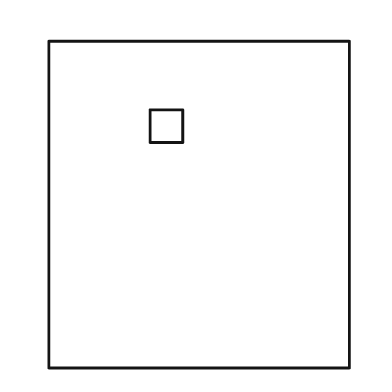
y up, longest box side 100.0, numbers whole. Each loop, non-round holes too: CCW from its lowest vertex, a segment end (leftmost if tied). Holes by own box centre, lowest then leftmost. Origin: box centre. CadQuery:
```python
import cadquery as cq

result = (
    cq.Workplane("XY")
    .moveTo(-46.0, -50.0)
    .lineTo(46.0, -50.0)
    .lineTo(46.0, 50.0)
    .lineTo(-46.0, 50.0)
    .close()
    .moveTo(-15.0, 19.0)
    .lineTo(-5.0, 19.0)
    .lineTo(-5.0, 29.0)
    .lineTo(-15.0, 29.0)
    .close()
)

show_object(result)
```